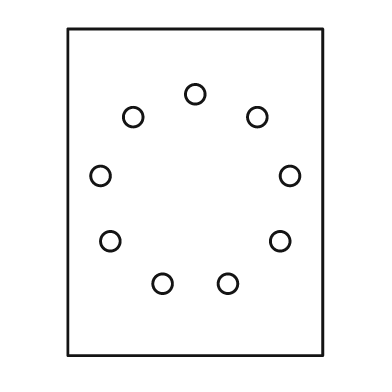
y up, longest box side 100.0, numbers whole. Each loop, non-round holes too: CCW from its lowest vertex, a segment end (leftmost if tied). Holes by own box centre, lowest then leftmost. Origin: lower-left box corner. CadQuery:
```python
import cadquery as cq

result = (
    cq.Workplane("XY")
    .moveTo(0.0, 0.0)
    .lineTo(78.0, 0.0)
    .lineTo(78.0, 100.0)
    .lineTo(0.0, 100.0)
    .close()
    .moveTo(29.0, 22.0)
    .circle(3.0)
    .moveTo(49.0, 22.0)
    .circle(3.0)
    .moveTo(13.0, 35.0)
    .circle(3.0)
    .moveTo(65.0, 35.0)
    .circle(3.0)
    .moveTo(10.0, 55.0)
    .circle(3.0)
    .moveTo(68.0, 55.0)
    .circle(3.0)
    .moveTo(20.0, 73.0)
    .circle(3.0)
    .moveTo(58.0, 73.0)
    .circle(3.0)
    .moveTo(39.0, 80.0)
    .circle(3.0)
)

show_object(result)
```